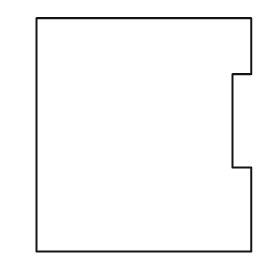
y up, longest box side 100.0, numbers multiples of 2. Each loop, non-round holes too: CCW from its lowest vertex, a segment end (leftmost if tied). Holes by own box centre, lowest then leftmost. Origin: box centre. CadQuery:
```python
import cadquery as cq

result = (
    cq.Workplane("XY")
    .moveTo(-46.0, -50.0)
    .lineTo(46.0, -50.0)
    .lineTo(46.0, -14.0)
    .lineTo(38.0, -14.0)
    .lineTo(38.0, 26.0)
    .lineTo(46.0, 26.0)
    .lineTo(46.0, 50.0)
    .lineTo(-46.0, 50.0)
    .close()
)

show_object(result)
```